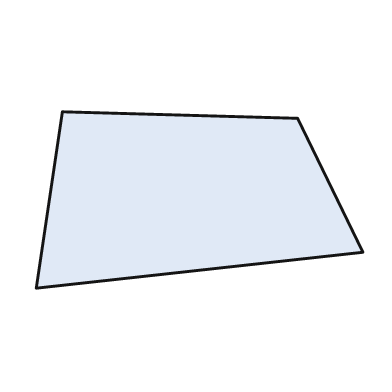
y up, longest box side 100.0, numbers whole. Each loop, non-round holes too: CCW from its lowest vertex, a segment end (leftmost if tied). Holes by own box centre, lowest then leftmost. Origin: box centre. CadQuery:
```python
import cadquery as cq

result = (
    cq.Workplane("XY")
    .moveTo(-50.0, -27.0)
    .lineTo(50.0, -16.0)
    .lineTo(30.0, 25.0)
    .lineTo(-42.0, 27.0)
    .close()
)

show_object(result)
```